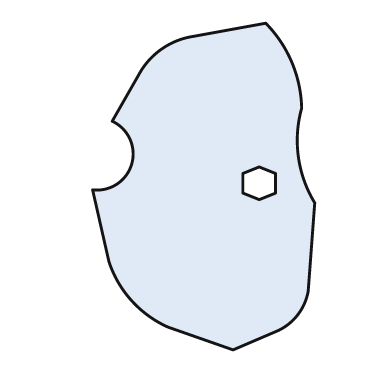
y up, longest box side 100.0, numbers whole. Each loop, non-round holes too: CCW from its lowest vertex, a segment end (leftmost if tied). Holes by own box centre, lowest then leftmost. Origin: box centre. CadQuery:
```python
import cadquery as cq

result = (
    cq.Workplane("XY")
    .moveTo(9.0, -50.0)
    .lineTo(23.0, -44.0)
    .threePointArc((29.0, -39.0), (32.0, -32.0))
    .lineTo(34.0, -5.0)
    .threePointArc((29.0, 9.0), (30.0, 24.0))
    .threePointArc((27.0, 38.0), (19.0, 50.0))
    .lineTo(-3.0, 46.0)
    .threePointArc((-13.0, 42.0), (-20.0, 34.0))
    .lineTo(-28.0, 20.0)
    .threePointArc((-22.0, 7.0), (-34.0, -1.0))
    .lineTo(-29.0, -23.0)
    .threePointArc((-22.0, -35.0), (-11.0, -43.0))
    .close()
    .moveTo(17.0, -4.0)
    .lineTo(22.0, -2.0)
    .lineTo(22.0, 4.0)
    .lineTo(17.0, 6.0)
    .lineTo(12.0, 4.0)
    .lineTo(12.0, -2.0)
    .close()
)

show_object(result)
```